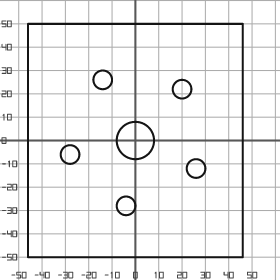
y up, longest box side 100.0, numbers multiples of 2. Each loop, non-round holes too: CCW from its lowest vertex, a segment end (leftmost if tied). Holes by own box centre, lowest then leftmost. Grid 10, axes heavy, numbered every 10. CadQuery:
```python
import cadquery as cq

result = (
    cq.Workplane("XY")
    .moveTo(-46.0, -50.0)
    .lineTo(46.0, -50.0)
    .lineTo(46.0, 50.0)
    .lineTo(-46.0, 50.0)
    .close()
    .moveTo(-4.0, -28.0)
    .circle(4.0)
    .moveTo(26.0, -12.0)
    .circle(4.0)
    .moveTo(-28.0, -6.0)
    .circle(4.0)
    .moveTo(0.0, 0.0)
    .circle(8.0)
    .moveTo(20.0, 22.0)
    .circle(4.0)
    .moveTo(-14.0, 26.0)
    .circle(4.0)
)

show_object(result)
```